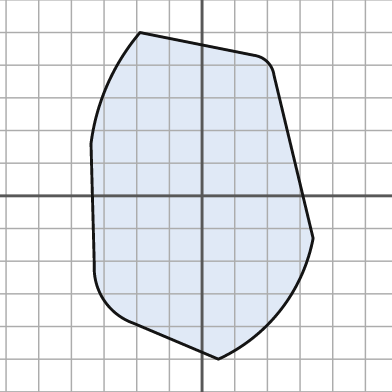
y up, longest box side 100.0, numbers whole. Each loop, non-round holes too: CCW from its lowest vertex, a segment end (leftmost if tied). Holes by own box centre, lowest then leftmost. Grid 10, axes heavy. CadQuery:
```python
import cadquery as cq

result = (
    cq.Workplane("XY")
    .moveTo(5.0, -50.0)
    .threePointArc((24.0, -35.0), (34.0, -13.0))
    .lineTo(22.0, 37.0)
    .threePointArc((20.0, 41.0), (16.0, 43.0))
    .lineTo(-19.0, 50.0)
    .threePointArc((-29.0, 34.0), (-34.0, 16.0))
    .lineTo(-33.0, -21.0)
    .threePointArc((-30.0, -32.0), (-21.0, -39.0))
    .close()
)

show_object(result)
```